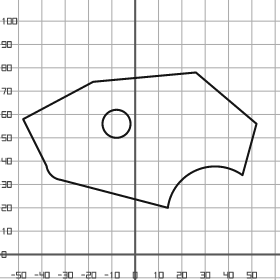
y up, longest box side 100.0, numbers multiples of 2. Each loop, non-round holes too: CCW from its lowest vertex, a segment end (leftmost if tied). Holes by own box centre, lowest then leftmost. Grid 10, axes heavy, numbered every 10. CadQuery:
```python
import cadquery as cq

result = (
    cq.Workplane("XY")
    .moveTo(14.0, 20.0)
    .threePointArc((26.0, 36.0), (46.0, 34.0))
    .lineTo(52.0, 56.0)
    .lineTo(26.0, 78.0)
    .lineTo(-18.0, 74.0)
    .lineTo(-48.0, 58.0)
    .lineTo(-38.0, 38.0)
    .threePointArc((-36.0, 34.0), (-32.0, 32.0))
    .close()
    .moveTo(-8.0, 56.0)
    .circle(6.0)
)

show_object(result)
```